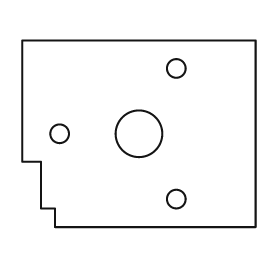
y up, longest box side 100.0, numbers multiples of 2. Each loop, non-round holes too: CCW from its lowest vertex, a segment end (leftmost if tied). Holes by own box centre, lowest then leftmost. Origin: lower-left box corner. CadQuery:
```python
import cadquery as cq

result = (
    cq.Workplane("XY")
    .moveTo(14.0, 0.0)
    .lineTo(100.0, 0.0)
    .lineTo(100.0, 80.0)
    .lineTo(0.0, 80.0)
    .lineTo(0.0, 28.0)
    .lineTo(8.0, 28.0)
    .lineTo(8.0, 8.0)
    .lineTo(14.0, 8.0)
    .close()
    .moveTo(66.0, 12.0)
    .circle(4.0)
    .moveTo(16.0, 40.0)
    .circle(4.0)
    .moveTo(50.0, 40.0)
    .circle(10.0)
    .moveTo(66.0, 68.0)
    .circle(4.0)
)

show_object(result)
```